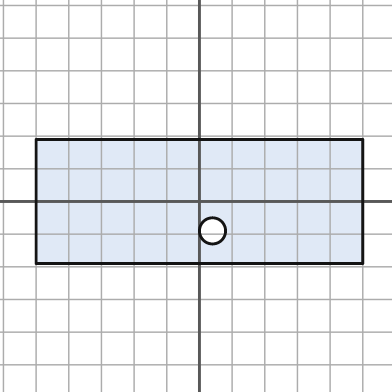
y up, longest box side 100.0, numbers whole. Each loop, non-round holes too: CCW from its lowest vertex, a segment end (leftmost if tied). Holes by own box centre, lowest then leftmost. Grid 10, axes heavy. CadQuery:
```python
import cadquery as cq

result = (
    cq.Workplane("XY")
    .moveTo(-50.0, -19.0)
    .lineTo(50.0, -19.0)
    .lineTo(50.0, 19.0)
    .lineTo(-50.0, 19.0)
    .close()
    .moveTo(4.0, -9.0)
    .circle(4.0)
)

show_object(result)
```